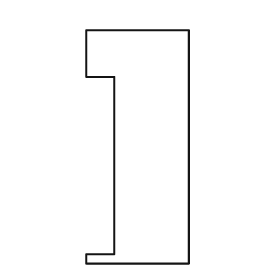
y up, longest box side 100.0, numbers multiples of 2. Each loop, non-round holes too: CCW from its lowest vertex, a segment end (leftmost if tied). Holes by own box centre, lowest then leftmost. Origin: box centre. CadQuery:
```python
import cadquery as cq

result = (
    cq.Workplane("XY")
    .moveTo(-22.0, -50.0)
    .lineTo(22.0, -50.0)
    .lineTo(22.0, 50.0)
    .lineTo(-22.0, 50.0)
    .lineTo(-22.0, 30.0)
    .lineTo(-10.0, 30.0)
    .lineTo(-10.0, -46.0)
    .lineTo(-22.0, -46.0)
    .close()
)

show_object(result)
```